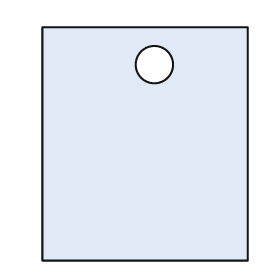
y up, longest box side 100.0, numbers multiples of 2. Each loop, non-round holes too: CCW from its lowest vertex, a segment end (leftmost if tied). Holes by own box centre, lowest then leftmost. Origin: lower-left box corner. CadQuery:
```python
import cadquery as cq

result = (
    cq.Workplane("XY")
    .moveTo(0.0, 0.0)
    .lineTo(88.0, 0.0)
    .lineTo(88.0, 100.0)
    .lineTo(0.0, 100.0)
    .close()
    .moveTo(48.0, 84.0)
    .circle(8.0)
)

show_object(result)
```